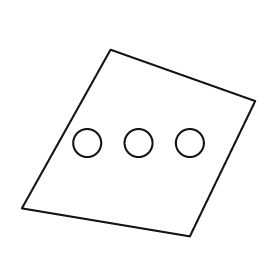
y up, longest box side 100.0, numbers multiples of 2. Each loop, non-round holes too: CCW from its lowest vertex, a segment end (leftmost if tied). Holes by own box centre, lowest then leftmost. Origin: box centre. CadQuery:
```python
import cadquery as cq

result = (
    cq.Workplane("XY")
    .moveTo(22.0, -40.0)
    .lineTo(50.0, 18.0)
    .lineTo(-12.0, 40.0)
    .lineTo(-50.0, -28.0)
    .close()
    .moveTo(-22.0, 0.0)
    .circle(6.0)
    .moveTo(0.0, 0.0)
    .circle(6.0)
    .moveTo(22.0, 0.0)
    .circle(6.0)
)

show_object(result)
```